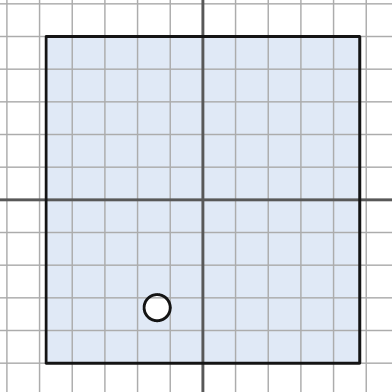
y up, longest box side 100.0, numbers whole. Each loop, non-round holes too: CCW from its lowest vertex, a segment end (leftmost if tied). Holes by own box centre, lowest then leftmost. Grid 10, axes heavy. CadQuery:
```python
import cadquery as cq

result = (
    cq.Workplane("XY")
    .moveTo(-48.0, -50.0)
    .lineTo(48.0, -50.0)
    .lineTo(48.0, 50.0)
    .lineTo(-48.0, 50.0)
    .close()
    .moveTo(-14.0, -33.0)
    .circle(4.0)
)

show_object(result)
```